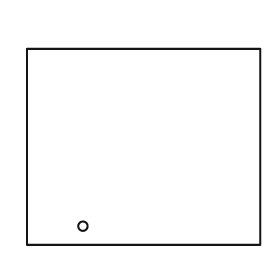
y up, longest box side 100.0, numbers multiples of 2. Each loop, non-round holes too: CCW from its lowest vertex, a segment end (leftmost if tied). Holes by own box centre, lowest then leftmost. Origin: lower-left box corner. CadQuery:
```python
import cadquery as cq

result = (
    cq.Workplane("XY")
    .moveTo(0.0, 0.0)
    .lineTo(100.0, 0.0)
    .lineTo(100.0, 84.0)
    .lineTo(0.0, 84.0)
    .close()
    .moveTo(24.0, 8.0)
    .circle(2.0)
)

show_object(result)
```